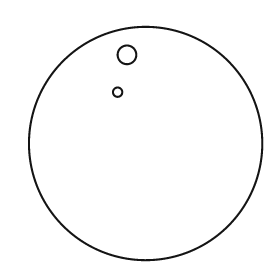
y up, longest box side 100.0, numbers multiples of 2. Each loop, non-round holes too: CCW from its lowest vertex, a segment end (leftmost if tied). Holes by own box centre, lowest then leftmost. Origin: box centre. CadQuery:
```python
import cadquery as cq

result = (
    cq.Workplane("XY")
    .moveTo(0.0, 0.0)
    .circle(50.0)
    .moveTo(-12.0, 22.0)
    .circle(2.0)
    .moveTo(-8.0, 38.0)
    .circle(4.0)
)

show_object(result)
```